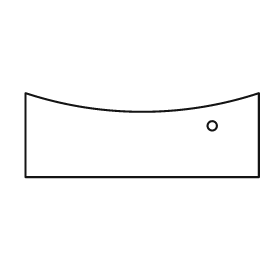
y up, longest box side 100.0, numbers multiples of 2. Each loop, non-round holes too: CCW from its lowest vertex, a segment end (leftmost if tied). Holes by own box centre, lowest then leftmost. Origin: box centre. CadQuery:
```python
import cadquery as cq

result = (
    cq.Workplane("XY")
    .moveTo(-50.0, -18.0)
    .lineTo(50.0, -18.0)
    .lineTo(50.0, 18.0)
    .threePointArc((0.0, 10.0), (-50.0, 18.0))
    .close()
    .moveTo(30.0, 4.0)
    .circle(2.0)
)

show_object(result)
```